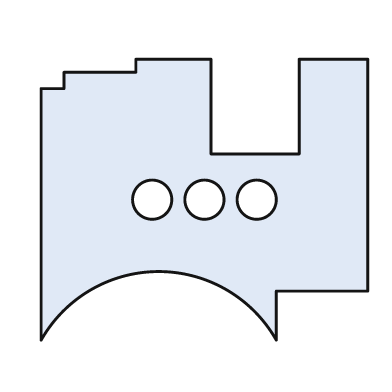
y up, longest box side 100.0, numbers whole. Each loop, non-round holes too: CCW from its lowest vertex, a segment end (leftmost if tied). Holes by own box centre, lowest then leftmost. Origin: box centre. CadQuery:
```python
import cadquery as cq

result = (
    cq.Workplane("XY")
    .moveTo(-50.0, -43.0)
    .threePointArc((-14.0, -22.0), (22.0, -43.0))
    .lineTo(22.0, -28.0)
    .lineTo(50.0, -28.0)
    .lineTo(50.0, 43.0)
    .lineTo(29.0, 43.0)
    .lineTo(29.0, 14.0)
    .lineTo(2.0, 14.0)
    .lineTo(2.0, 43.0)
    .lineTo(-21.0, 43.0)
    .lineTo(-21.0, 39.0)
    .lineTo(-43.0, 39.0)
    .lineTo(-43.0, 34.0)
    .lineTo(-50.0, 34.0)
    .close()
    .moveTo(-16.0, 0.0)
    .circle(6.0)
    .moveTo(0.0, 0.0)
    .circle(6.0)
    .moveTo(16.0, 0.0)
    .circle(6.0)
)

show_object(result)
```